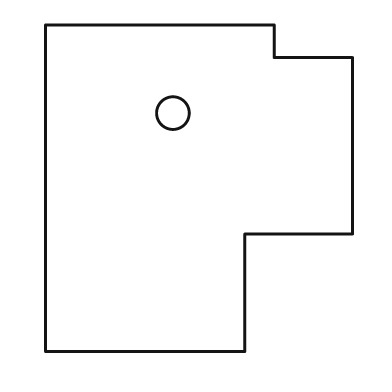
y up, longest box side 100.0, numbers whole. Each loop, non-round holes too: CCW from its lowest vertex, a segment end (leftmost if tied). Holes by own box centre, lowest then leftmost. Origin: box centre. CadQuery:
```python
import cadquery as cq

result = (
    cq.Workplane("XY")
    .moveTo(-47.0, -50.0)
    .lineTo(14.0, -50.0)
    .lineTo(14.0, -14.0)
    .lineTo(47.0, -14.0)
    .lineTo(47.0, 40.0)
    .lineTo(23.0, 40.0)
    .lineTo(23.0, 50.0)
    .lineTo(-47.0, 50.0)
    .close()
    .moveTo(-8.0, 23.0)
    .circle(5.0)
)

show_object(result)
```